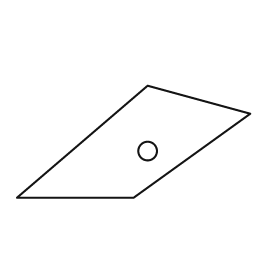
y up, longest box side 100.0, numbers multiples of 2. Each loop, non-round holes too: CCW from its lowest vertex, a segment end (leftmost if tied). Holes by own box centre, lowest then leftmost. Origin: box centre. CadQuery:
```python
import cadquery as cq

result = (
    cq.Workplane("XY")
    .moveTo(-50.0, -24.0)
    .lineTo(0.0, -24.0)
    .lineTo(50.0, 12.0)
    .lineTo(6.0, 24.0)
    .close()
    .moveTo(6.0, -4.0)
    .circle(4.0)
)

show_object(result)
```